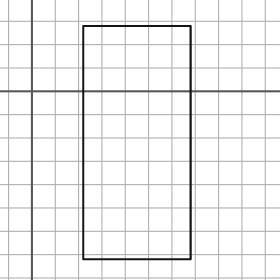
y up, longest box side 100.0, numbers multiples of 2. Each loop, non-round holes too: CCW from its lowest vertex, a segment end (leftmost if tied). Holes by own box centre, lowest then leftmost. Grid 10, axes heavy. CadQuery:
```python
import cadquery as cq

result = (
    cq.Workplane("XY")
    .moveTo(22.0, -72.0)
    .lineTo(68.0, -72.0)
    .lineTo(68.0, 28.0)
    .lineTo(22.0, 28.0)
    .close()
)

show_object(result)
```